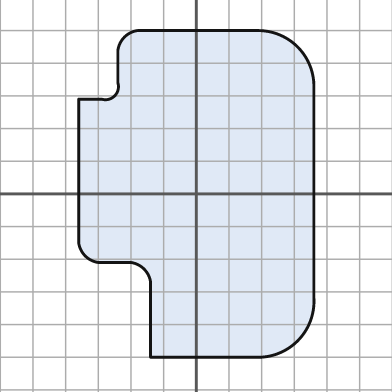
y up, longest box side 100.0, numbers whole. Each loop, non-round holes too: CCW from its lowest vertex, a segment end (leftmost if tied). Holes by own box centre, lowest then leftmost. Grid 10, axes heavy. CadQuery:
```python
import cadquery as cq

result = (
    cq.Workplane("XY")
    .moveTo(-14.0, -50.0)
    .lineTo(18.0, -50.0)
    .threePointArc((31.0, -45.0), (36.0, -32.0))
    .lineTo(36.0, 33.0)
    .threePointArc((31.0, 45.0), (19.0, 50.0))
    .lineTo(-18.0, 50.0)
    .threePointArc((-22.0, 48.0), (-24.0, 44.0))
    .lineTo(-24.0, 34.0)
    .threePointArc((-25.0, 30.0), (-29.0, 29.0))
    .lineTo(-36.0, 29.0)
    .lineTo(-36.0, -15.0)
    .threePointArc((-34.0, -19.0), (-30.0, -21.0))
    .lineTo(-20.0, -21.0)
    .threePointArc((-16.0, -23.0), (-14.0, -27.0))
    .close()
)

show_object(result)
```